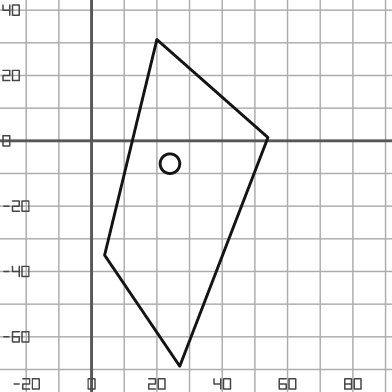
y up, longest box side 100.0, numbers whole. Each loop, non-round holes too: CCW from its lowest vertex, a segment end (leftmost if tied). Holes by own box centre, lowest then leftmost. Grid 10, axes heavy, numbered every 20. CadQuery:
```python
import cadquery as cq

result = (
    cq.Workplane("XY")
    .moveTo(27.0, -69.0)
    .lineTo(54.0, 1.0)
    .lineTo(20.0, 31.0)
    .lineTo(4.0, -35.0)
    .close()
    .moveTo(24.0, -7.0)
    .circle(3.0)
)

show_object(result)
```